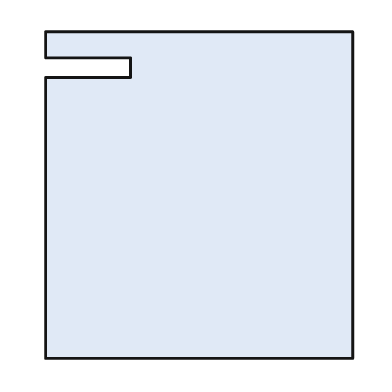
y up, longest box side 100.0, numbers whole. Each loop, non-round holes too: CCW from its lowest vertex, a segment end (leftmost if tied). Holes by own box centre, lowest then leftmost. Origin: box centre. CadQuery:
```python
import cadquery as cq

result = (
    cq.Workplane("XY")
    .moveTo(-47.0, -50.0)
    .lineTo(47.0, -50.0)
    .lineTo(47.0, 50.0)
    .lineTo(-47.0, 50.0)
    .lineTo(-47.0, 42.0)
    .lineTo(-21.0, 42.0)
    .lineTo(-21.0, 36.0)
    .lineTo(-47.0, 36.0)
    .close()
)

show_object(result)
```